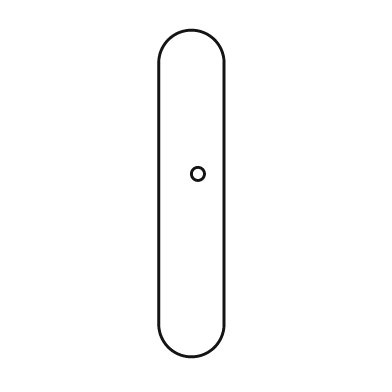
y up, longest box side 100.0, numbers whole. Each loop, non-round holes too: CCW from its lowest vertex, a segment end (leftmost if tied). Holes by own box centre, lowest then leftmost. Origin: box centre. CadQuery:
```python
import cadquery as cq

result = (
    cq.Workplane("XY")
    .moveTo(-10.0, -40.0)
    .threePointArc((0.0, -50.0), (10.0, -40.0))
    .lineTo(10.0, 40.0)
    .threePointArc((0.0, 50.0), (-10.0, 40.0))
    .close()
    .moveTo(2.0, 6.0)
    .circle(2.0)
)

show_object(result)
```